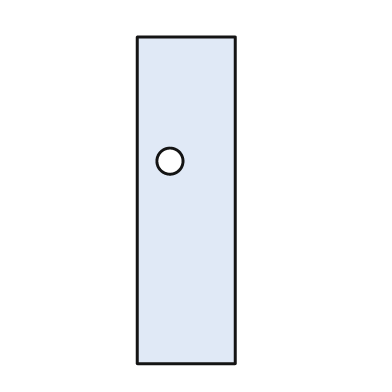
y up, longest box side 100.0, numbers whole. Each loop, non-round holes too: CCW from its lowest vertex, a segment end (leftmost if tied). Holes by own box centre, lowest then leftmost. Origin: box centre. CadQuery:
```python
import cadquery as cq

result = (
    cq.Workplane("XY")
    .moveTo(-15.0, -50.0)
    .lineTo(15.0, -50.0)
    .lineTo(15.0, 50.0)
    .lineTo(-15.0, 50.0)
    .close()
    .moveTo(-5.0, 12.0)
    .circle(4.0)
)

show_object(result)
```